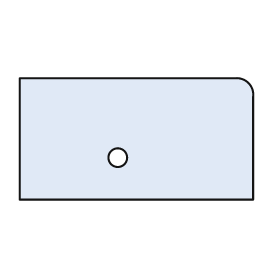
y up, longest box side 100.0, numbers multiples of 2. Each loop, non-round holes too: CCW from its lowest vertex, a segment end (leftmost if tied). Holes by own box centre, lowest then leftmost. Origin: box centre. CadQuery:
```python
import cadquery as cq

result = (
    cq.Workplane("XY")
    .moveTo(-50.0, -26.0)
    .lineTo(50.0, -26.0)
    .lineTo(50.0, 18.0)
    .threePointArc((48.0, 24.0), (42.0, 26.0))
    .lineTo(-50.0, 26.0)
    .close()
    .moveTo(-8.0, -8.0)
    .circle(4.0)
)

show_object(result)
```